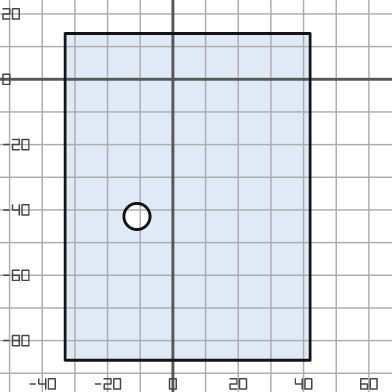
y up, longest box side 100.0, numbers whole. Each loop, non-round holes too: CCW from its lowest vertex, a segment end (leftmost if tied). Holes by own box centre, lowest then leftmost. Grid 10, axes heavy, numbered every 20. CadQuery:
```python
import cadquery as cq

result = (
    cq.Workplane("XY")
    .moveTo(-33.0, -86.0)
    .lineTo(42.0, -86.0)
    .lineTo(42.0, 14.0)
    .lineTo(-33.0, 14.0)
    .close()
    .moveTo(-11.0, -42.0)
    .circle(4.0)
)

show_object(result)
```